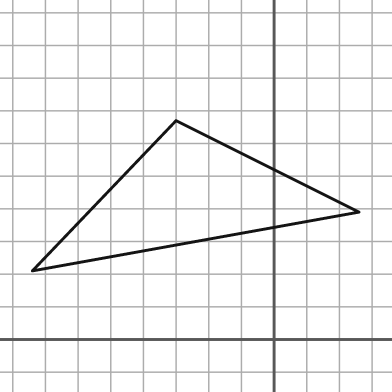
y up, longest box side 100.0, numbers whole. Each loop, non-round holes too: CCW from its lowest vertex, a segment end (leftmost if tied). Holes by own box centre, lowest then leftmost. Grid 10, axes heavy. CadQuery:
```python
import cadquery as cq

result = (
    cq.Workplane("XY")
    .moveTo(-74.0, 21.0)
    .lineTo(26.0, 39.0)
    .lineTo(-30.0, 67.0)
    .close()
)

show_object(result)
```